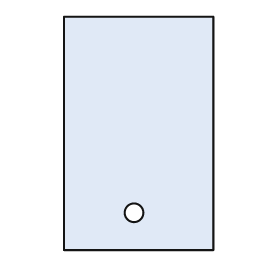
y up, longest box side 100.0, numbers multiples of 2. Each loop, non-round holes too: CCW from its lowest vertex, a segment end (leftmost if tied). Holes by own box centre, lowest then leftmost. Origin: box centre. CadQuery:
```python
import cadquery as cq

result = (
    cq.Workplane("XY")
    .moveTo(-32.0, -50.0)
    .lineTo(32.0, -50.0)
    .lineTo(32.0, 50.0)
    .lineTo(-32.0, 50.0)
    .close()
    .moveTo(-2.0, -34.0)
    .circle(4.0)
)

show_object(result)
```